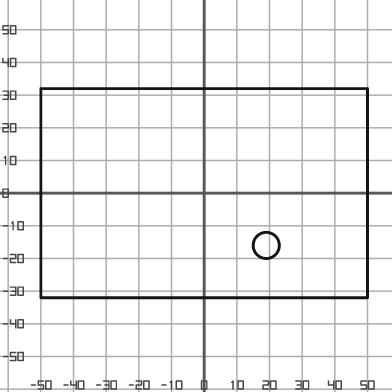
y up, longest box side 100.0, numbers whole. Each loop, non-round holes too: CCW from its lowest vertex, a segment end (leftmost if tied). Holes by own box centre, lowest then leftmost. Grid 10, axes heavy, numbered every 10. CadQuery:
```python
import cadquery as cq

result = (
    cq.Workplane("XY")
    .moveTo(-50.0, -32.0)
    .lineTo(50.0, -32.0)
    .lineTo(50.0, 32.0)
    .lineTo(-50.0, 32.0)
    .close()
    .moveTo(19.0, -16.0)
    .circle(4.0)
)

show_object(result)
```